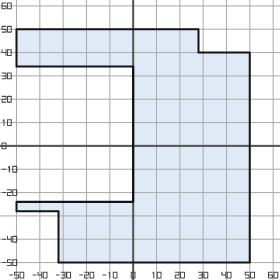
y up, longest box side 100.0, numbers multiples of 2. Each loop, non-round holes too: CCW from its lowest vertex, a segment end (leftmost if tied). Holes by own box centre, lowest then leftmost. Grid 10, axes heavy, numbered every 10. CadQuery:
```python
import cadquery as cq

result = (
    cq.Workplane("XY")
    .moveTo(-32.0, -50.0)
    .lineTo(50.0, -50.0)
    .lineTo(50.0, 40.0)
    .lineTo(28.0, 40.0)
    .lineTo(28.0, 50.0)
    .lineTo(-50.0, 50.0)
    .lineTo(-50.0, 34.0)
    .lineTo(0.0, 34.0)
    .lineTo(0.0, -24.0)
    .lineTo(-50.0, -24.0)
    .lineTo(-50.0, -28.0)
    .lineTo(-32.0, -28.0)
    .close()
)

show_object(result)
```